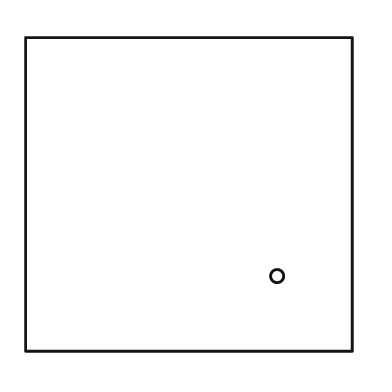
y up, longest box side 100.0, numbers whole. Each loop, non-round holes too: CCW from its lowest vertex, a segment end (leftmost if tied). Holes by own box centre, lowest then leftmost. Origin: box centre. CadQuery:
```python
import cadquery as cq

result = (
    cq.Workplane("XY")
    .moveTo(-50.0, -48.0)
    .lineTo(50.0, -48.0)
    .lineTo(50.0, 48.0)
    .lineTo(-50.0, 48.0)
    .close()
    .moveTo(27.0, -25.0)
    .circle(2.0)
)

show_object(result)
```